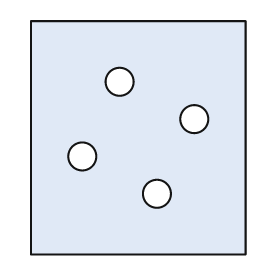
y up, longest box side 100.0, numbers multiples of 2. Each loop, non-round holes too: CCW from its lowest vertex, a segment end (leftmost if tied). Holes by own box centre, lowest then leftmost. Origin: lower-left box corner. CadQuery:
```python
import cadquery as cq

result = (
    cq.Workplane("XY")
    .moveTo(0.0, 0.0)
    .lineTo(92.0, 0.0)
    .lineTo(92.0, 100.0)
    .lineTo(0.0, 100.0)
    .close()
    .moveTo(54.0, 26.0)
    .circle(6.0)
    .moveTo(22.0, 42.0)
    .circle(6.0)
    .moveTo(70.0, 58.0)
    .circle(6.0)
    .moveTo(38.0, 74.0)
    .circle(6.0)
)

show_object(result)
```